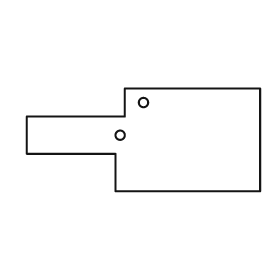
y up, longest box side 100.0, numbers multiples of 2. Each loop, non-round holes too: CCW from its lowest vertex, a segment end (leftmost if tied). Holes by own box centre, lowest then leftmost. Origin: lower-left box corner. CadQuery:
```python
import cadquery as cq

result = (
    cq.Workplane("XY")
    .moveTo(38.0, 0.0)
    .lineTo(100.0, 0.0)
    .lineTo(100.0, 44.0)
    .lineTo(42.0, 44.0)
    .lineTo(42.0, 32.0)
    .lineTo(0.0, 32.0)
    .lineTo(0.0, 16.0)
    .lineTo(38.0, 16.0)
    .close()
    .moveTo(40.0, 24.0)
    .circle(2.0)
    .moveTo(50.0, 38.0)
    .circle(2.0)
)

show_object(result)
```